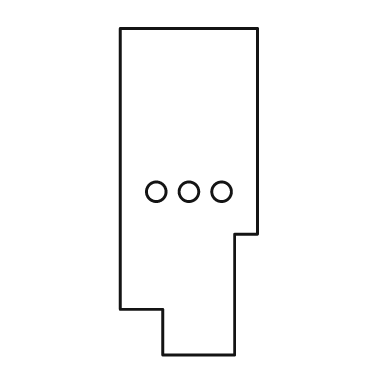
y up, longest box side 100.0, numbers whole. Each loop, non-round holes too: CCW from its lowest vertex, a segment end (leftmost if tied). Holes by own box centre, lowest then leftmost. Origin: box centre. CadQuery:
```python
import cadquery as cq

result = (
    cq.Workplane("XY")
    .moveTo(-8.0, -50.0)
    .lineTo(14.0, -50.0)
    .lineTo(14.0, -13.0)
    .lineTo(21.0, -13.0)
    .lineTo(21.0, 50.0)
    .lineTo(-21.0, 50.0)
    .lineTo(-21.0, -36.0)
    .lineTo(-8.0, -36.0)
    .close()
    .moveTo(-10.0, 0.0)
    .circle(3.0)
    .moveTo(0.0, 0.0)
    .circle(3.0)
    .moveTo(10.0, 0.0)
    .circle(3.0)
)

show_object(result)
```